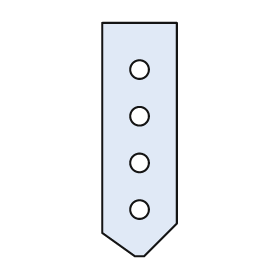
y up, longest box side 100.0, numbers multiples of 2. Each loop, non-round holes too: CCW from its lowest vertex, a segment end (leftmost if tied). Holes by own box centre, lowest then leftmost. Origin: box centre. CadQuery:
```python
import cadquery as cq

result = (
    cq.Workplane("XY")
    .moveTo(-2.0, -50.0)
    .lineTo(2.0, -50.0)
    .lineTo(16.0, -36.0)
    .lineTo(16.0, 50.0)
    .lineTo(-16.0, 50.0)
    .lineTo(-16.0, -40.0)
    .close()
    .moveTo(0.0, -30.0)
    .circle(4.0)
    .moveTo(0.0, -10.0)
    .circle(4.0)
    .moveTo(0.0, 10.0)
    .circle(4.0)
    .moveTo(0.0, 30.0)
    .circle(4.0)
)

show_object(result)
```